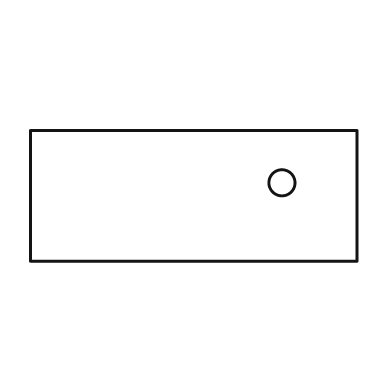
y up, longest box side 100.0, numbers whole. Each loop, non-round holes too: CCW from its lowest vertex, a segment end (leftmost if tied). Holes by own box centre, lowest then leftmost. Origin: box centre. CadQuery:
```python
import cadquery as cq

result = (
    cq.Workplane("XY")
    .moveTo(-50.0, -20.0)
    .lineTo(50.0, -20.0)
    .lineTo(50.0, 20.0)
    .lineTo(-50.0, 20.0)
    .close()
    .moveTo(27.0, 4.0)
    .circle(4.0)
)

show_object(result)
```